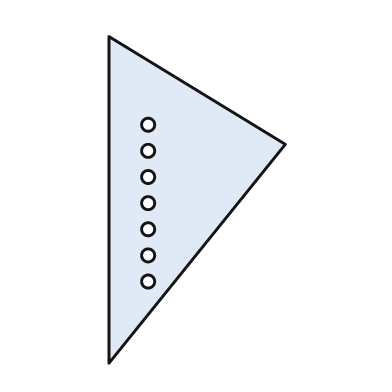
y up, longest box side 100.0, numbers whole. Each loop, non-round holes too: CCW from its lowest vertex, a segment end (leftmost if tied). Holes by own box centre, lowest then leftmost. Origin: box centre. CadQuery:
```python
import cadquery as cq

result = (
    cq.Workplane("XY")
    .moveTo(-27.0, -50.0)
    .lineTo(27.0, 17.0)
    .lineTo(-27.0, 50.0)
    .close()
    .moveTo(-15.0, -25.0)
    .circle(2.0)
    .moveTo(-15.0, -17.0)
    .circle(2.0)
    .moveTo(-15.0, -9.0)
    .circle(2.0)
    .moveTo(-15.0, -1.0)
    .circle(2.0)
    .moveTo(-15.0, 7.0)
    .circle(2.0)
    .moveTo(-15.0, 15.0)
    .circle(2.0)
    .moveTo(-15.0, 23.0)
    .circle(2.0)
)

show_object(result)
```